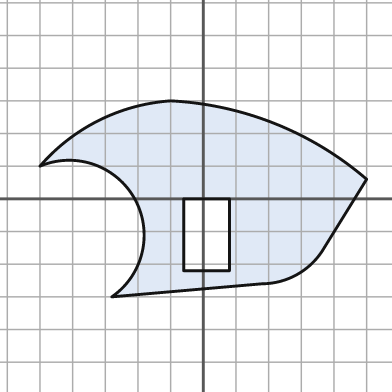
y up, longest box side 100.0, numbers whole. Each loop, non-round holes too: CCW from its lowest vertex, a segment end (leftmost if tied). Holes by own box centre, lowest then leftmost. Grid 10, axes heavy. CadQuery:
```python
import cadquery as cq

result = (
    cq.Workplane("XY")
    .moveTo(-28.0, -30.0)
    .lineTo(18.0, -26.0)
    .threePointArc((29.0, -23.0), (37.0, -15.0))
    .lineTo(50.0, 6.0)
    .threePointArc((22.0, 23.0), (-10.0, 30.0))
    .threePointArc((-32.0, 24.0), (-50.0, 10.0))
    .threePointArc((-21.0, 0.0), (-28.0, -30.0))
    .close()
    .moveTo(-6.0, -22.0)
    .lineTo(8.0, -22.0)
    .lineTo(8.0, 0.0)
    .lineTo(-6.0, 0.0)
    .close()
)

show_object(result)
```